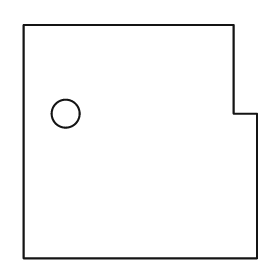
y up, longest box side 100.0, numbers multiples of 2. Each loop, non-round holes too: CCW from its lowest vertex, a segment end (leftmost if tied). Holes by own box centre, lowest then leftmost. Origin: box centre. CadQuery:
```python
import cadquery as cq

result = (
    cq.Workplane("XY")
    .moveTo(-50.0, -50.0)
    .lineTo(50.0, -50.0)
    .lineTo(50.0, 12.0)
    .lineTo(40.0, 12.0)
    .lineTo(40.0, 50.0)
    .lineTo(-50.0, 50.0)
    .close()
    .moveTo(-32.0, 12.0)
    .circle(6.0)
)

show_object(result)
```